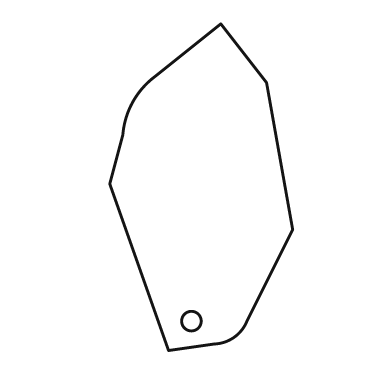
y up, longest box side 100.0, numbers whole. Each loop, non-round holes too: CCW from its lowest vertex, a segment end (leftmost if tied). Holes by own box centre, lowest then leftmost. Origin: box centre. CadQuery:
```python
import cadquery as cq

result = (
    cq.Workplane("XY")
    .moveTo(-10.0, -50.0)
    .lineTo(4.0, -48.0)
    .threePointArc((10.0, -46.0), (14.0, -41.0))
    .lineTo(28.0, -13.0)
    .lineTo(20.0, 32.0)
    .lineTo(6.0, 50.0)
    .lineTo(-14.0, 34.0)
    .threePointArc((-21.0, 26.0), (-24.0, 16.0))
    .lineTo(-28.0, 1.0)
    .close()
    .moveTo(-3.0, -41.0)
    .circle(3.0)
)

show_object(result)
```